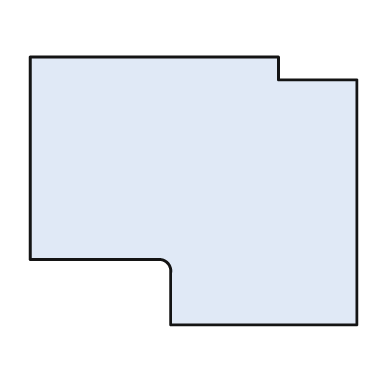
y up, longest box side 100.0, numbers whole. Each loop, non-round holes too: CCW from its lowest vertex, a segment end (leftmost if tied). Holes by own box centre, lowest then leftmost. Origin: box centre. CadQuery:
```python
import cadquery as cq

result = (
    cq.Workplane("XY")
    .moveTo(-7.0, -41.0)
    .lineTo(50.0, -41.0)
    .lineTo(50.0, 34.0)
    .lineTo(26.0, 34.0)
    .lineTo(26.0, 41.0)
    .lineTo(-50.0, 41.0)
    .lineTo(-50.0, -21.0)
    .lineTo(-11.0, -21.0)
    .threePointArc((-8.0, -22.0), (-7.0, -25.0))
    .close()
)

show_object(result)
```